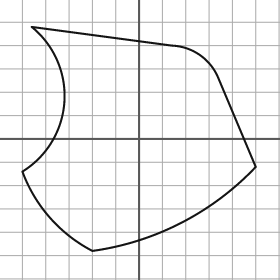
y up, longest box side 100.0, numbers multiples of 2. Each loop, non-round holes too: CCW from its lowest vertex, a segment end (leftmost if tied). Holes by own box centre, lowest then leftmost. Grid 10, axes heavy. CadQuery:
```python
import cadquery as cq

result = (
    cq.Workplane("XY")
    .moveTo(-20.0, -48.0)
    .threePointArc((18.0, -36.0), (50.0, -12.0))
    .lineTo(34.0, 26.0)
    .threePointArc((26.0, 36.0), (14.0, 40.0))
    .lineTo(-46.0, 48.0)
    .threePointArc((-32.0, 16.0), (-50.0, -14.0))
    .threePointArc((-38.0, -34.0), (-20.0, -48.0))
    .close()
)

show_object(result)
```